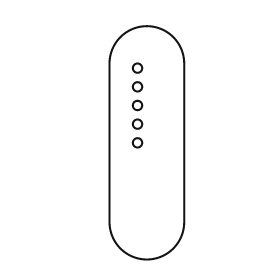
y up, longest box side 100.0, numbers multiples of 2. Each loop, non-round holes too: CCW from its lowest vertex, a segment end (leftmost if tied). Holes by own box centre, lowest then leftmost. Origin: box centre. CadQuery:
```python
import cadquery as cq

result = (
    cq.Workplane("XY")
    .moveTo(-16.0, -34.0)
    .threePointArc((0.0, -50.0), (16.0, -34.0))
    .lineTo(16.0, 34.0)
    .threePointArc((0.0, 50.0), (-16.0, 34.0))
    .close()
    .moveTo(-4.0, 0.0)
    .circle(2.0)
    .moveTo(-4.0, 8.0)
    .circle(2.0)
    .moveTo(-4.0, 16.0)
    .circle(2.0)
    .moveTo(-4.0, 24.0)
    .circle(2.0)
    .moveTo(-4.0, 32.0)
    .circle(2.0)
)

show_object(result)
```